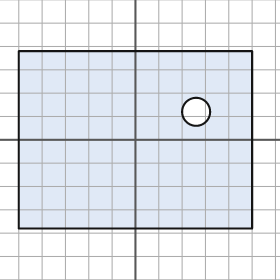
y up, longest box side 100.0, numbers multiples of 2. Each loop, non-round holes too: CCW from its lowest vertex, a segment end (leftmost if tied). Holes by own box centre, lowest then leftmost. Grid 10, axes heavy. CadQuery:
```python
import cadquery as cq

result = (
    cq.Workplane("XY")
    .moveTo(-50.0, -38.0)
    .lineTo(50.0, -38.0)
    .lineTo(50.0, 38.0)
    .lineTo(-50.0, 38.0)
    .close()
    .moveTo(26.0, 12.0)
    .circle(6.0)
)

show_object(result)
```